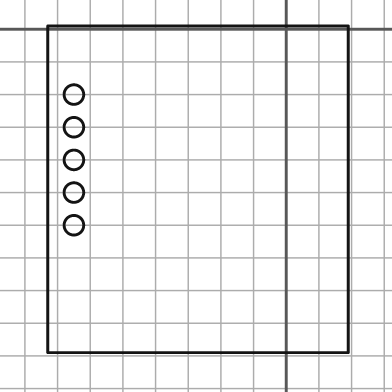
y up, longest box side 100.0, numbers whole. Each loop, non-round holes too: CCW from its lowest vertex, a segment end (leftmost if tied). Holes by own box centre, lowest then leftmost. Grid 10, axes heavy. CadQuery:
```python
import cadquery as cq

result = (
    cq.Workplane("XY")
    .moveTo(-73.0, -99.0)
    .lineTo(19.0, -99.0)
    .lineTo(19.0, 1.0)
    .lineTo(-73.0, 1.0)
    .close()
    .moveTo(-65.0, -60.0)
    .circle(3.0)
    .moveTo(-65.0, -50.0)
    .circle(3.0)
    .moveTo(-65.0, -40.0)
    .circle(3.0)
    .moveTo(-65.0, -30.0)
    .circle(3.0)
    .moveTo(-65.0, -20.0)
    .circle(3.0)
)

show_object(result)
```